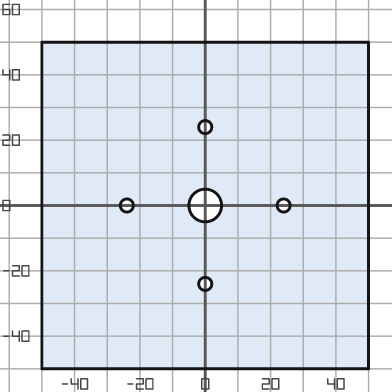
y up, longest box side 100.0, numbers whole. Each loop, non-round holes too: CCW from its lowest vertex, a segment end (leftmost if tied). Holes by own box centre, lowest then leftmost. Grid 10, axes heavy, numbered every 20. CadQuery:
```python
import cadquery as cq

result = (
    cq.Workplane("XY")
    .moveTo(-50.0, -50.0)
    .lineTo(50.0, -50.0)
    .lineTo(50.0, 50.0)
    .lineTo(-50.0, 50.0)
    .close()
    .moveTo(0.0, -24.0)
    .circle(2.0)
    .moveTo(-24.0, 0.0)
    .circle(2.0)
    .moveTo(0.0, 0.0)
    .circle(5.0)
    .moveTo(24.0, 0.0)
    .circle(2.0)
    .moveTo(0.0, 24.0)
    .circle(2.0)
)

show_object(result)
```